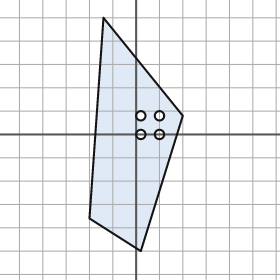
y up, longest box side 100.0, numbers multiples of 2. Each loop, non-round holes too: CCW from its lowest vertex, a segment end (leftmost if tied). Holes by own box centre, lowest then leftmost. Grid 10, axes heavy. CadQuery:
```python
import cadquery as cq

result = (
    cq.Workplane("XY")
    .moveTo(2.0, -50.0)
    .lineTo(20.0, 8.0)
    .lineTo(-14.0, 50.0)
    .lineTo(-20.0, -36.0)
    .close()
    .moveTo(2.0, 0.0)
    .circle(2.0)
    .moveTo(10.0, 0.0)
    .circle(2.0)
    .moveTo(2.0, 8.0)
    .circle(2.0)
    .moveTo(10.0, 8.0)
    .circle(2.0)
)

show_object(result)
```